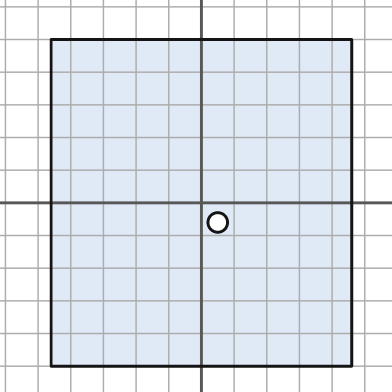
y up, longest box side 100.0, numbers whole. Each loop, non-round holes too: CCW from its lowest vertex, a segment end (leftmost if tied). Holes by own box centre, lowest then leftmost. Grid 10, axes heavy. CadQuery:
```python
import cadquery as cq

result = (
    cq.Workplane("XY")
    .moveTo(-46.0, -50.0)
    .lineTo(46.0, -50.0)
    .lineTo(46.0, 50.0)
    .lineTo(-46.0, 50.0)
    .close()
    .moveTo(5.0, -6.0)
    .circle(3.0)
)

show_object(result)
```